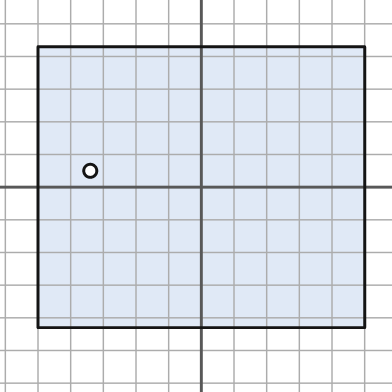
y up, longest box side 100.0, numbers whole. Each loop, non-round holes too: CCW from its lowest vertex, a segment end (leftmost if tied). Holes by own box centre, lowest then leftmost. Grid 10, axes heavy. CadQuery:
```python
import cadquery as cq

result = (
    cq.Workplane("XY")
    .moveTo(-50.0, -43.0)
    .lineTo(50.0, -43.0)
    .lineTo(50.0, 43.0)
    .lineTo(-50.0, 43.0)
    .close()
    .moveTo(-34.0, 5.0)
    .circle(2.0)
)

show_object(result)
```